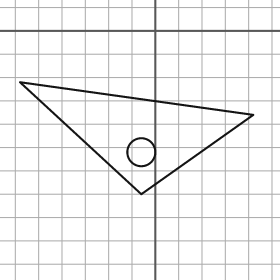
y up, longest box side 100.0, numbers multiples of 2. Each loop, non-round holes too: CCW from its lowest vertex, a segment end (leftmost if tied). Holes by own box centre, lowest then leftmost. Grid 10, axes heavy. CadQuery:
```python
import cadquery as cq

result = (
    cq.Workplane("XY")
    .moveTo(-6.0, -70.0)
    .lineTo(42.0, -36.0)
    .lineTo(-58.0, -22.0)
    .close()
    .moveTo(-6.0, -52.0)
    .circle(6.0)
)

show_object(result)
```